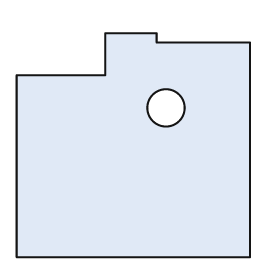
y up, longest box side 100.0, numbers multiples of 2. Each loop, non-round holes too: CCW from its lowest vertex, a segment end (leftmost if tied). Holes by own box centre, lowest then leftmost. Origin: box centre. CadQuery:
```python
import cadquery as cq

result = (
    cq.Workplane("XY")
    .moveTo(-50.0, -48.0)
    .lineTo(50.0, -48.0)
    .lineTo(50.0, 44.0)
    .lineTo(10.0, 44.0)
    .lineTo(10.0, 48.0)
    .lineTo(-12.0, 48.0)
    .lineTo(-12.0, 30.0)
    .lineTo(-50.0, 30.0)
    .close()
    .moveTo(14.0, 16.0)
    .circle(8.0)
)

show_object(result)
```